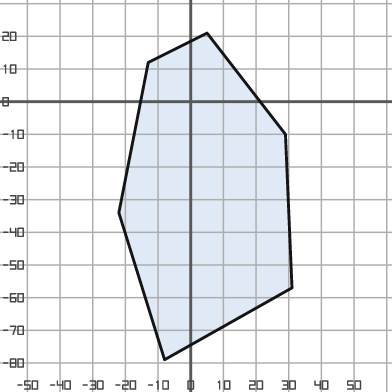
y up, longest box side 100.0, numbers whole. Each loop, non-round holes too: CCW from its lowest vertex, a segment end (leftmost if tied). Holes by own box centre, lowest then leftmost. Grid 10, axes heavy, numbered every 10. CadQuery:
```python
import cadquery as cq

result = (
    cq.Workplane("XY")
    .moveTo(-8.0, -79.0)
    .lineTo(31.0, -57.0)
    .lineTo(29.0, -10.0)
    .lineTo(5.0, 21.0)
    .lineTo(-13.0, 12.0)
    .lineTo(-22.0, -34.0)
    .close()
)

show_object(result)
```